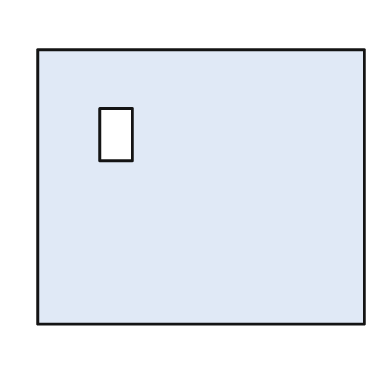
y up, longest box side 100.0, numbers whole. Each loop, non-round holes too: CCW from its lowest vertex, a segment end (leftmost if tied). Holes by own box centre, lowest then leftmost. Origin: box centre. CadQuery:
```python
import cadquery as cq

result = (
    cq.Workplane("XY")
    .moveTo(-50.0, -42.0)
    .lineTo(50.0, -42.0)
    .lineTo(50.0, 42.0)
    .lineTo(-50.0, 42.0)
    .close()
    .moveTo(-31.0, 8.0)
    .lineTo(-21.0, 8.0)
    .lineTo(-21.0, 24.0)
    .lineTo(-31.0, 24.0)
    .close()
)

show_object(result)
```